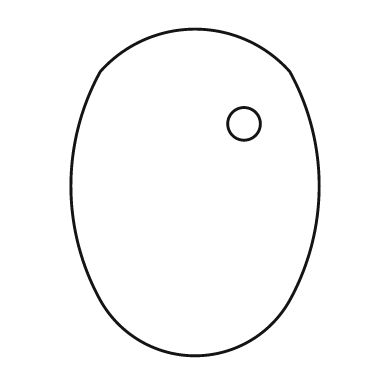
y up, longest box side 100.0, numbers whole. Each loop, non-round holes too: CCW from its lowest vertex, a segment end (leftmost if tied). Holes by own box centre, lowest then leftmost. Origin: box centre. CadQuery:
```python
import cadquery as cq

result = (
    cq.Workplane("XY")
    .moveTo(-29.0, -33.0)
    .threePointArc((0.0, -50.0), (29.0, -33.0))
    .threePointArc((38.0, 2.0), (29.0, 37.0))
    .threePointArc((0.0, 50.0), (-29.0, 37.0))
    .threePointArc((-38.0, 2.0), (-29.0, -33.0))
    .close()
    .moveTo(15.0, 21.0)
    .circle(5.0)
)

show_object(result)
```